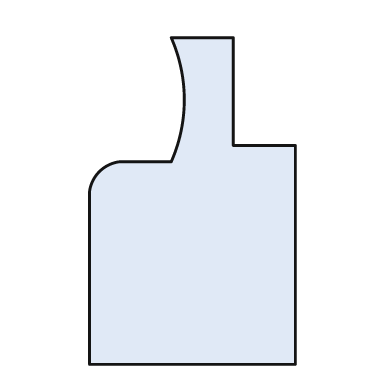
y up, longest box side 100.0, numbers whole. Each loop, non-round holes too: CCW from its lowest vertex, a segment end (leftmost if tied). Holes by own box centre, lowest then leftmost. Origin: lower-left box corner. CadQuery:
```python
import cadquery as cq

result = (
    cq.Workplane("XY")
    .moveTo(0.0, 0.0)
    .lineTo(63.0, 0.0)
    .lineTo(63.0, 67.0)
    .lineTo(44.0, 67.0)
    .lineTo(44.0, 100.0)
    .lineTo(25.0, 100.0)
    .threePointArc((29.0, 81.0), (25.0, 62.0))
    .lineTo(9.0, 62.0)
    .threePointArc((3.0, 59.0), (0.0, 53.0))
    .close()
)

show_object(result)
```